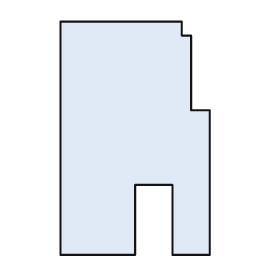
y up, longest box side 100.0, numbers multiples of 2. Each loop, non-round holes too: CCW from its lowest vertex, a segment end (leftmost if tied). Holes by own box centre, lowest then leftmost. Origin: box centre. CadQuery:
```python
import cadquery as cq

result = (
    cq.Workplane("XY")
    .moveTo(-32.0, -50.0)
    .lineTo(0.0, -50.0)
    .lineTo(0.0, -20.0)
    .lineTo(16.0, -20.0)
    .lineTo(16.0, -50.0)
    .lineTo(32.0, -50.0)
    .lineTo(32.0, 12.0)
    .lineTo(24.0, 12.0)
    .lineTo(24.0, 44.0)
    .lineTo(20.0, 44.0)
    .lineTo(20.0, 50.0)
    .lineTo(-32.0, 50.0)
    .close()
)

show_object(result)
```